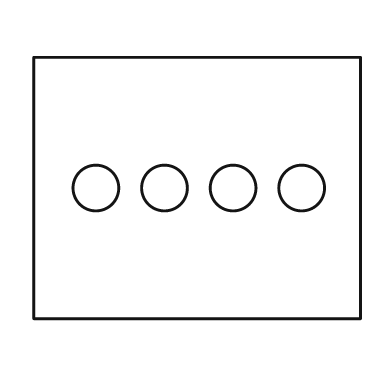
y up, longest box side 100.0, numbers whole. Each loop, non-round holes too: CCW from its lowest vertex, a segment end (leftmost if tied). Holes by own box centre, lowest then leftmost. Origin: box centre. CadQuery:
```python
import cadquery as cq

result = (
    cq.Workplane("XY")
    .moveTo(-50.0, -40.0)
    .lineTo(50.0, -40.0)
    .lineTo(50.0, 40.0)
    .lineTo(-50.0, 40.0)
    .close()
    .moveTo(-31.0, 0.0)
    .circle(7.0)
    .moveTo(-10.0, 0.0)
    .circle(7.0)
    .moveTo(11.0, 0.0)
    .circle(7.0)
    .moveTo(32.0, 0.0)
    .circle(7.0)
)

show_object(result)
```